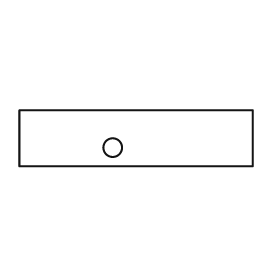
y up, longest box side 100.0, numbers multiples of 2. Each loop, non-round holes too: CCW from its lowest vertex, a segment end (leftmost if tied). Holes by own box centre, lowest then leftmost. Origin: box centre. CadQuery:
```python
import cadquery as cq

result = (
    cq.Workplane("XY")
    .moveTo(-50.0, -12.0)
    .lineTo(50.0, -12.0)
    .lineTo(50.0, 12.0)
    .lineTo(-50.0, 12.0)
    .close()
    .moveTo(-10.0, -4.0)
    .circle(4.0)
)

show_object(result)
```